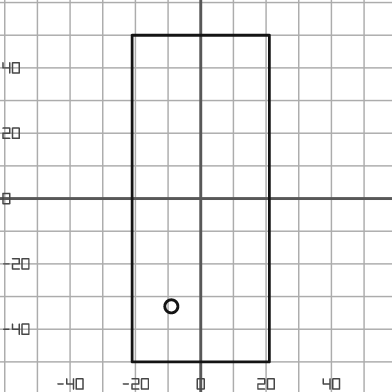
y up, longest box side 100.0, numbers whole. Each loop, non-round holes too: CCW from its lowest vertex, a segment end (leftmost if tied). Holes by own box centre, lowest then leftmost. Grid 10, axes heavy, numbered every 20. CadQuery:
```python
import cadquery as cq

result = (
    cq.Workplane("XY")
    .moveTo(-21.0, -50.0)
    .lineTo(21.0, -50.0)
    .lineTo(21.0, 50.0)
    .lineTo(-21.0, 50.0)
    .close()
    .moveTo(-9.0, -33.0)
    .circle(2.0)
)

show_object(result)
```